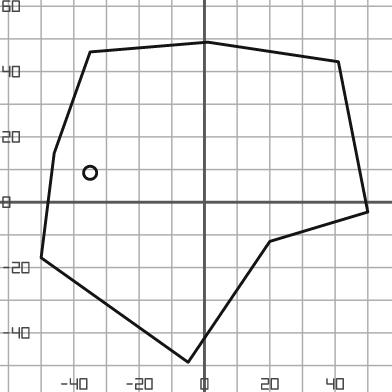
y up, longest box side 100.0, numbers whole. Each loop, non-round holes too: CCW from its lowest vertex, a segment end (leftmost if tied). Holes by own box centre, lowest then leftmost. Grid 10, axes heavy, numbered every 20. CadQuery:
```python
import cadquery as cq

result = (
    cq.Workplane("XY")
    .moveTo(-5.0, -49.0)
    .lineTo(20.0, -12.0)
    .lineTo(50.0, -3.0)
    .lineTo(41.0, 43.0)
    .lineTo(1.0, 49.0)
    .lineTo(-35.0, 46.0)
    .lineTo(-46.0, 15.0)
    .lineTo(-50.0, -17.0)
    .close()
    .moveTo(-35.0, 9.0)
    .circle(2.0)
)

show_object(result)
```